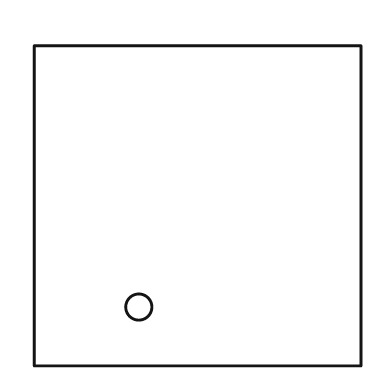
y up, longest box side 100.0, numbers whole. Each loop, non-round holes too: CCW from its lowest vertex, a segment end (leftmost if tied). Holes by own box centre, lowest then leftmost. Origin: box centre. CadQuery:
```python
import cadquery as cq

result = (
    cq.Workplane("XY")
    .moveTo(-50.0, -49.0)
    .lineTo(50.0, -49.0)
    .lineTo(50.0, 49.0)
    .lineTo(-50.0, 49.0)
    .close()
    .moveTo(-18.0, -31.0)
    .circle(4.0)
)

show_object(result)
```